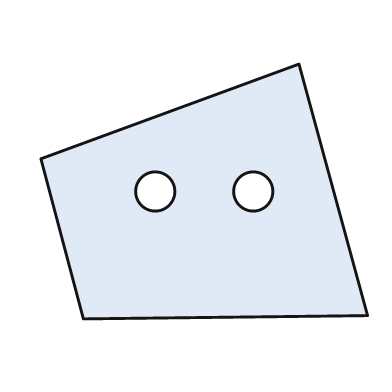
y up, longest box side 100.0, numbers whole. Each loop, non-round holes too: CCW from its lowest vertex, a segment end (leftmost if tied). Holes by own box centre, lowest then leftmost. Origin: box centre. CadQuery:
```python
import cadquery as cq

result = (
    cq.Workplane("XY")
    .moveTo(-37.0, -39.0)
    .lineTo(50.0, -38.0)
    .lineTo(29.0, 39.0)
    .lineTo(-50.0, 10.0)
    .close()
    .moveTo(-15.0, 0.0)
    .circle(6.0)
    .moveTo(15.0, 0.0)
    .circle(6.0)
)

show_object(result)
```